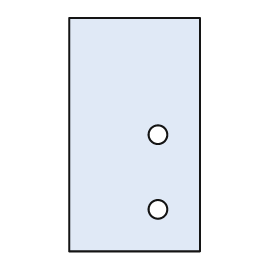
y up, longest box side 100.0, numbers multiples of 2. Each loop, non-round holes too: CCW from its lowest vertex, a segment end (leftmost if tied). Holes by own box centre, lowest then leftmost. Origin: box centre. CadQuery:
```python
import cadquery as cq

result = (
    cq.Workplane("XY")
    .moveTo(-28.0, -50.0)
    .lineTo(28.0, -50.0)
    .lineTo(28.0, 50.0)
    .lineTo(-28.0, 50.0)
    .close()
    .moveTo(10.0, -32.0)
    .circle(4.0)
    .moveTo(10.0, 0.0)
    .circle(4.0)
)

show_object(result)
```